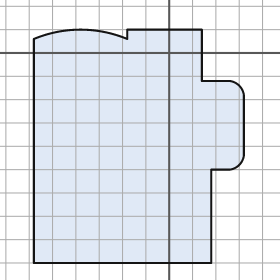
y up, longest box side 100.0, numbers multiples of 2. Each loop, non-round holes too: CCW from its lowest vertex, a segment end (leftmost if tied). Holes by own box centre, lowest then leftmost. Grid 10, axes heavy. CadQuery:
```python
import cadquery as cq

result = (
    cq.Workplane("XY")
    .moveTo(-58.0, -90.0)
    .lineTo(18.0, -90.0)
    .lineTo(18.0, -50.0)
    .lineTo(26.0, -50.0)
    .threePointArc((30.0, -48.0), (32.0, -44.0))
    .lineTo(32.0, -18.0)
    .threePointArc((30.0, -14.0), (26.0, -12.0))
    .lineTo(14.0, -12.0)
    .lineTo(14.0, 10.0)
    .lineTo(-18.0, 10.0)
    .lineTo(-18.0, 6.0)
    .threePointArc((-38.0, 10.0), (-58.0, 6.0))
    .close()
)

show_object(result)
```